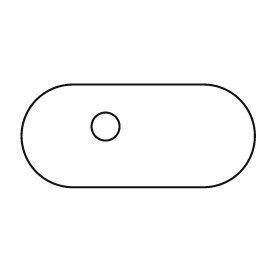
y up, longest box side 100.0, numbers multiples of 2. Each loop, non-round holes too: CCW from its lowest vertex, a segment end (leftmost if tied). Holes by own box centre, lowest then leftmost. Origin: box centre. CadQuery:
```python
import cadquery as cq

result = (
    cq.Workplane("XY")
    .moveTo(-28.0, -22.0)
    .lineTo(28.0, -22.0)
    .threePointArc((50.0, 0.0), (28.0, 22.0))
    .lineTo(-28.0, 22.0)
    .threePointArc((-50.0, 0.0), (-28.0, -22.0))
    .close()
    .moveTo(-14.0, 4.0)
    .circle(6.0)
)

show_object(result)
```